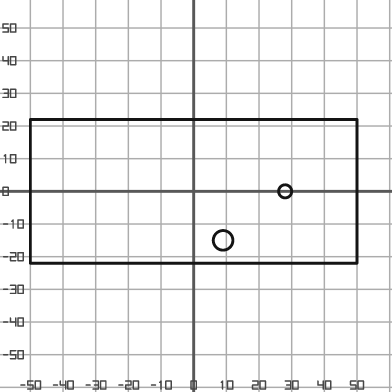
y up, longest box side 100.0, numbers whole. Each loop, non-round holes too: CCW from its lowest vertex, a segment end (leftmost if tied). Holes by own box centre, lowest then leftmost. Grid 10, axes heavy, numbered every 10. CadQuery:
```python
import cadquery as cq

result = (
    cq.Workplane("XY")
    .moveTo(-50.0, -22.0)
    .lineTo(50.0, -22.0)
    .lineTo(50.0, 22.0)
    .lineTo(-50.0, 22.0)
    .close()
    .moveTo(9.0, -15.0)
    .circle(3.0)
    .moveTo(28.0, 0.0)
    .circle(2.0)
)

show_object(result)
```